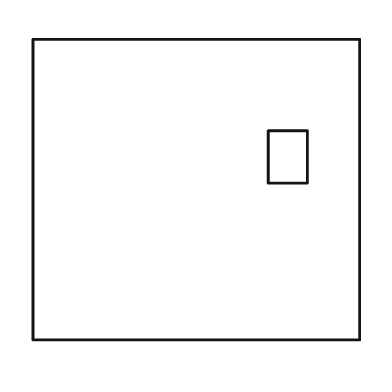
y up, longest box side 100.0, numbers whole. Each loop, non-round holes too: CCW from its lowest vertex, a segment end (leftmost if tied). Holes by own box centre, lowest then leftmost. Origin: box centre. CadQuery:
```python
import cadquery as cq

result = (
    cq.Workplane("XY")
    .moveTo(-50.0, -46.0)
    .lineTo(50.0, -46.0)
    .lineTo(50.0, 46.0)
    .lineTo(-50.0, 46.0)
    .close()
    .moveTo(22.0, 2.0)
    .lineTo(34.0, 2.0)
    .lineTo(34.0, 18.0)
    .lineTo(22.0, 18.0)
    .close()
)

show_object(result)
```